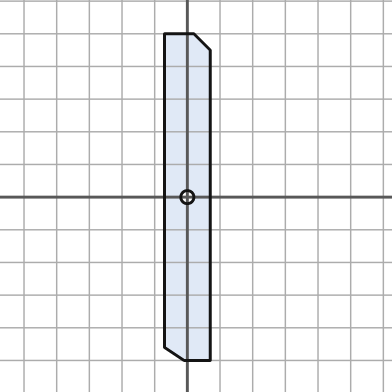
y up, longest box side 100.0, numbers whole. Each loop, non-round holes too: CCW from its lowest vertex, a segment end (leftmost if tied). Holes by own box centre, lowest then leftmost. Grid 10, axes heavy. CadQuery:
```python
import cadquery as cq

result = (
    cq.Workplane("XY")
    .moveTo(-1.0, -50.0)
    .lineTo(7.0, -50.0)
    .lineTo(7.0, 45.0)
    .lineTo(2.0, 50.0)
    .lineTo(-7.0, 50.0)
    .lineTo(-7.0, -46.0)
    .close()
    .moveTo(0.0, 0.0)
    .circle(2.0)
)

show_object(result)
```